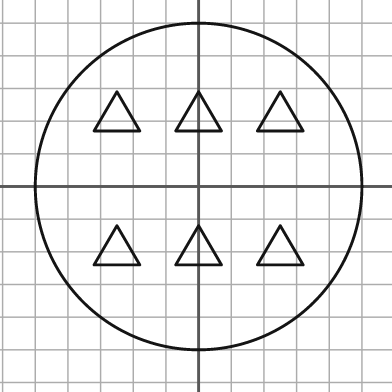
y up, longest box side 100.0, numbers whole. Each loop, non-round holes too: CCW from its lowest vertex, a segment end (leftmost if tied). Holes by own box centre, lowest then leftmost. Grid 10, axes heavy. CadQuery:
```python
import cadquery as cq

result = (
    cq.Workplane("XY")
    .moveTo(0.0, 0.0)
    .circle(50.0)
    .moveTo(-32.0, -24.0)
    .lineTo(-18.0, -24.0)
    .lineTo(-25.0, -12.0)
    .close()
    .moveTo(-7.0, -24.0)
    .lineTo(7.0, -24.0)
    .lineTo(0.0, -12.0)
    .close()
    .moveTo(18.0, -24.0)
    .lineTo(32.0, -24.0)
    .lineTo(25.0, -12.0)
    .close()
    .moveTo(-32.0, 17.0)
    .lineTo(-18.0, 17.0)
    .lineTo(-25.0, 29.0)
    .close()
    .moveTo(-7.0, 17.0)
    .lineTo(7.0, 17.0)
    .lineTo(0.0, 29.0)
    .close()
    .moveTo(18.0, 17.0)
    .lineTo(32.0, 17.0)
    .lineTo(25.0, 29.0)
    .close()
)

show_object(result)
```